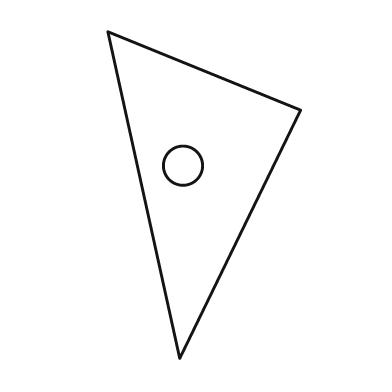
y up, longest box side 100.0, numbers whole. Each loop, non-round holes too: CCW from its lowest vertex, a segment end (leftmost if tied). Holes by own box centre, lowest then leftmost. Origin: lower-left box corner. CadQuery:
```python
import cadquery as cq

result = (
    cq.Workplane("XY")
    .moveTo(22.0, 0.0)
    .lineTo(59.0, 76.0)
    .lineTo(0.0, 100.0)
    .close()
    .moveTo(23.0, 59.0)
    .circle(6.0)
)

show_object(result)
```